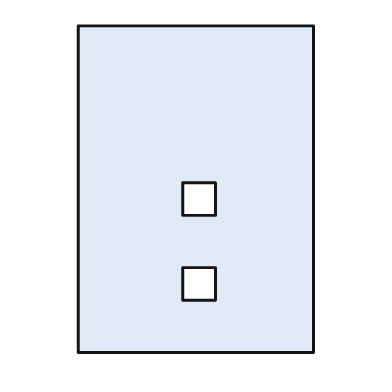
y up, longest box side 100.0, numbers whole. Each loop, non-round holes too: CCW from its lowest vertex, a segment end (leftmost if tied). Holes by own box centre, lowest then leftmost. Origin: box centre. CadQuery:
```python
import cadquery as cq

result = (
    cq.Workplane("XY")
    .moveTo(-36.0, -50.0)
    .lineTo(36.0, -50.0)
    .lineTo(36.0, 50.0)
    .lineTo(-36.0, 50.0)
    .close()
    .moveTo(-4.0, -34.0)
    .lineTo(6.0, -34.0)
    .lineTo(6.0, -24.0)
    .lineTo(-4.0, -24.0)
    .close()
    .moveTo(-4.0, -8.0)
    .lineTo(6.0, -8.0)
    .lineTo(6.0, 2.0)
    .lineTo(-4.0, 2.0)
    .close()
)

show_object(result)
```